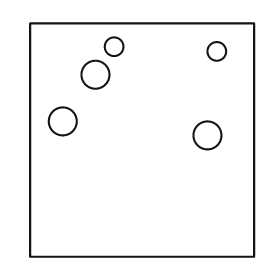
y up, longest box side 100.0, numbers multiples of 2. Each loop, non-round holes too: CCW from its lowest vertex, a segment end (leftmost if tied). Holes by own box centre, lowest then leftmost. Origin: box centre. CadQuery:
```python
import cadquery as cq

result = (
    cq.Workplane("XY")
    .moveTo(-48.0, -50.0)
    .lineTo(48.0, -50.0)
    .lineTo(48.0, 50.0)
    .lineTo(-48.0, 50.0)
    .close()
    .moveTo(28.0, 2.0)
    .circle(6.0)
    .moveTo(-34.0, 8.0)
    .circle(6.0)
    .moveTo(-20.0, 28.0)
    .circle(6.0)
    .moveTo(32.0, 38.0)
    .circle(4.0)
    .moveTo(-12.0, 40.0)
    .circle(4.0)
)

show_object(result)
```